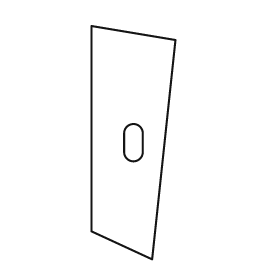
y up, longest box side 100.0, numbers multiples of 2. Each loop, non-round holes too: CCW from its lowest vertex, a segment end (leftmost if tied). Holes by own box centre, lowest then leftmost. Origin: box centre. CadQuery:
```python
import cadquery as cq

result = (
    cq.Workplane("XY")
    .moveTo(8.0, -50.0)
    .lineTo(18.0, 44.0)
    .lineTo(-18.0, 50.0)
    .lineTo(-18.0, -38.0)
    .close()
    .moveTo(-4.0, -4.0)
    .threePointArc((0.0, -8.0), (4.0, -4.0))
    .lineTo(4.0, 4.0)
    .threePointArc((0.0, 8.0), (-4.0, 4.0))
    .close()
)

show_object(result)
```